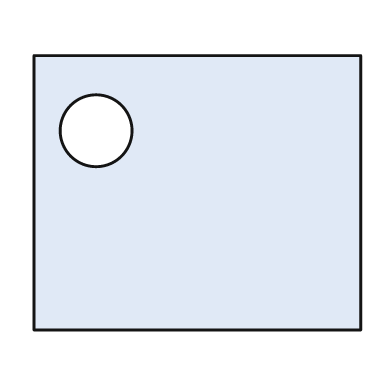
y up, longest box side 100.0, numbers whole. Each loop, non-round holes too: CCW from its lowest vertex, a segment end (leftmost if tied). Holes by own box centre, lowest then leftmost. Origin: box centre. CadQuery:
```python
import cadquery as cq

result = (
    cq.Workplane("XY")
    .moveTo(-50.0, -42.0)
    .lineTo(50.0, -42.0)
    .lineTo(50.0, 42.0)
    .lineTo(-50.0, 42.0)
    .close()
    .moveTo(-31.0, 19.0)
    .circle(11.0)
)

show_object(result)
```